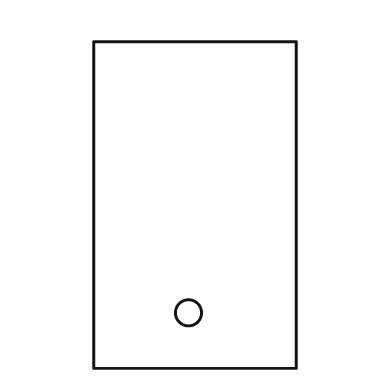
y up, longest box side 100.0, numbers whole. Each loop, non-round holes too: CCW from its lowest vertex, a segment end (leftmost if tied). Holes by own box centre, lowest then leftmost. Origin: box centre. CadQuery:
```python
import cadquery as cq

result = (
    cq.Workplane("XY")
    .moveTo(-31.0, -50.0)
    .lineTo(31.0, -50.0)
    .lineTo(31.0, 50.0)
    .lineTo(-31.0, 50.0)
    .close()
    .moveTo(-2.0, -33.0)
    .circle(4.0)
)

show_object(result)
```